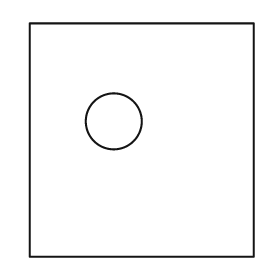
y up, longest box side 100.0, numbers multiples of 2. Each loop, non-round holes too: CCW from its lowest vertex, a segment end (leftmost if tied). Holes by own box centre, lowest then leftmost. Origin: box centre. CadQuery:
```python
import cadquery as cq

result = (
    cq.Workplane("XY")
    .moveTo(-48.0, -50.0)
    .lineTo(48.0, -50.0)
    .lineTo(48.0, 50.0)
    .lineTo(-48.0, 50.0)
    .close()
    .moveTo(-12.0, 8.0)
    .circle(12.0)
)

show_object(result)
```